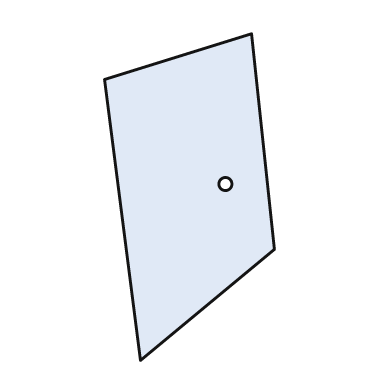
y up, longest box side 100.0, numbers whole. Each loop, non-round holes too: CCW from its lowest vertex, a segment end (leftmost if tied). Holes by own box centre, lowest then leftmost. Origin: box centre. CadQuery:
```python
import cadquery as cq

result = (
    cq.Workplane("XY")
    .moveTo(-15.0, -50.0)
    .lineTo(26.0, -16.0)
    .lineTo(19.0, 50.0)
    .lineTo(-26.0, 36.0)
    .close()
    .moveTo(11.0, 4.0)
    .circle(2.0)
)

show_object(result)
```